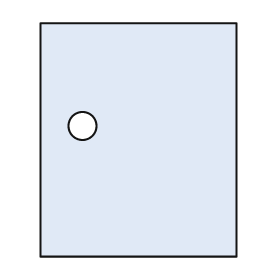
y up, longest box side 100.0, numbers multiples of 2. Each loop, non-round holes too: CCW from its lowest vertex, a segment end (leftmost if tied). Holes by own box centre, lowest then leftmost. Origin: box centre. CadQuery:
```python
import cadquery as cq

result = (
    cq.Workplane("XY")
    .moveTo(-42.0, -50.0)
    .lineTo(42.0, -50.0)
    .lineTo(42.0, 50.0)
    .lineTo(-42.0, 50.0)
    .close()
    .moveTo(-24.0, 6.0)
    .circle(6.0)
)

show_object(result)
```